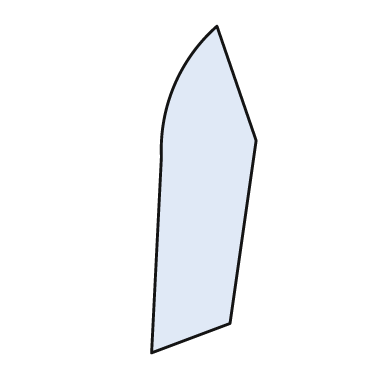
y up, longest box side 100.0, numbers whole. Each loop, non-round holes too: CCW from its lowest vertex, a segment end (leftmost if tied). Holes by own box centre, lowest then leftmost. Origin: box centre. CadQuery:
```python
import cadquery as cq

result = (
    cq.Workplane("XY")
    .moveTo(-16.0, -50.0)
    .lineTo(8.0, -41.0)
    .lineTo(16.0, 15.0)
    .lineTo(4.0, 50.0)
    .threePointArc((-9.0, 32.0), (-13.0, 10.0))
    .close()
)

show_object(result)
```